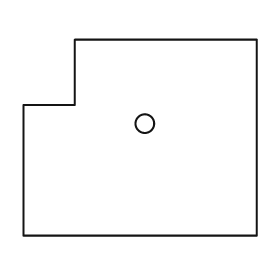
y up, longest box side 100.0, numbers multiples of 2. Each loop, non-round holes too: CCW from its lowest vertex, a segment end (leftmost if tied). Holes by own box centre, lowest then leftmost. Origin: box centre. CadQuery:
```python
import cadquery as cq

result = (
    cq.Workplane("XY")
    .moveTo(-50.0, -42.0)
    .lineTo(50.0, -42.0)
    .lineTo(50.0, 42.0)
    .lineTo(-28.0, 42.0)
    .lineTo(-28.0, 14.0)
    .lineTo(-50.0, 14.0)
    .close()
    .moveTo(2.0, 6.0)
    .circle(4.0)
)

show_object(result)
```